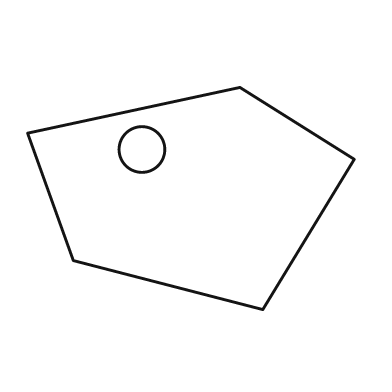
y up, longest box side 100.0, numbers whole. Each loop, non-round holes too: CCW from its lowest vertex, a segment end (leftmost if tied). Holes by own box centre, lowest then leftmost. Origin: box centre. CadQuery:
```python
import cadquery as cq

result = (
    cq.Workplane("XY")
    .moveTo(22.0, -34.0)
    .lineTo(50.0, 12.0)
    .lineTo(15.0, 34.0)
    .lineTo(-50.0, 20.0)
    .lineTo(-36.0, -19.0)
    .close()
    .moveTo(-15.0, 15.0)
    .circle(7.0)
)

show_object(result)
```